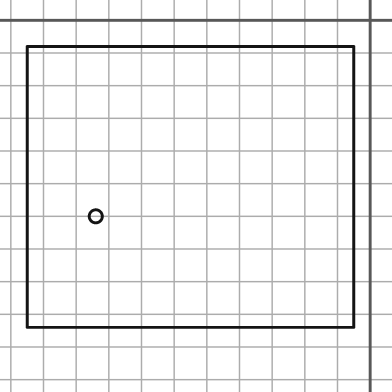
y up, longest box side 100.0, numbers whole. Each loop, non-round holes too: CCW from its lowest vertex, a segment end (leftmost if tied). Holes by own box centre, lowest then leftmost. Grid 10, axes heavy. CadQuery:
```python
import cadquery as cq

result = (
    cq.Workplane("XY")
    .moveTo(-105.0, -94.0)
    .lineTo(-5.0, -94.0)
    .lineTo(-5.0, -8.0)
    .lineTo(-105.0, -8.0)
    .close()
    .moveTo(-84.0, -60.0)
    .circle(2.0)
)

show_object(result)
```